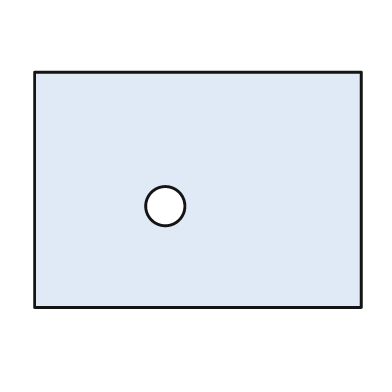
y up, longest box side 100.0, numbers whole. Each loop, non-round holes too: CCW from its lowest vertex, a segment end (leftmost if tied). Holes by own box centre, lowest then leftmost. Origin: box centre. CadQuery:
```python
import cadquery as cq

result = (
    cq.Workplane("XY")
    .moveTo(-50.0, -36.0)
    .lineTo(50.0, -36.0)
    .lineTo(50.0, 36.0)
    .lineTo(-50.0, 36.0)
    .close()
    .moveTo(-10.0, -5.0)
    .circle(6.0)
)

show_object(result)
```